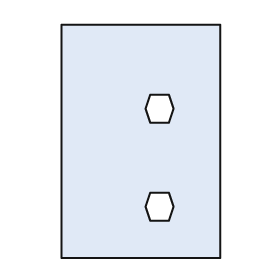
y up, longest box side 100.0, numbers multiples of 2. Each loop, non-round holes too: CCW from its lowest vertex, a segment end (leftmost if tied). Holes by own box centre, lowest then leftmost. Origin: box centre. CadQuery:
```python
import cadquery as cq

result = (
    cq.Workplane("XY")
    .moveTo(-34.0, -50.0)
    .lineTo(34.0, -50.0)
    .lineTo(34.0, 50.0)
    .lineTo(-34.0, 50.0)
    .close()
    .moveTo(4.0, -34.0)
    .lineTo(12.0, -34.0)
    .lineTo(14.0, -28.0)
    .lineTo(12.0, -22.0)
    .lineTo(4.0, -22.0)
    .lineTo(2.0, -28.0)
    .close()
    .moveTo(4.0, 8.0)
    .lineTo(12.0, 8.0)
    .lineTo(14.0, 14.0)
    .lineTo(12.0, 20.0)
    .lineTo(4.0, 20.0)
    .lineTo(2.0, 14.0)
    .close()
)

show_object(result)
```